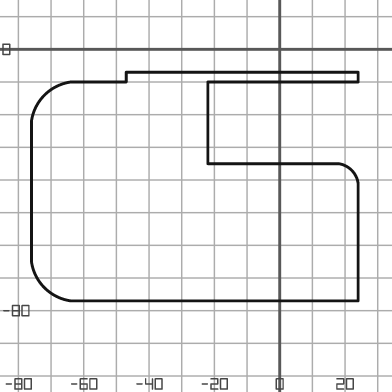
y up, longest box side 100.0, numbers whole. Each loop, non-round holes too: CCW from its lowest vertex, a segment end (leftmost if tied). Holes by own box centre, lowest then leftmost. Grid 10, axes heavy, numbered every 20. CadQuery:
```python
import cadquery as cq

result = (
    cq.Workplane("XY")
    .moveTo(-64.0, -77.0)
    .lineTo(24.0, -77.0)
    .lineTo(24.0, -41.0)
    .threePointArc((22.0, -37.0), (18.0, -35.0))
    .lineTo(-22.0, -35.0)
    .lineTo(-22.0, -10.0)
    .lineTo(24.0, -10.0)
    .lineTo(24.0, -7.0)
    .lineTo(-47.0, -7.0)
    .lineTo(-47.0, -10.0)
    .lineTo(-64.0, -10.0)
    .threePointArc((-72.0, -14.0), (-76.0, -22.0))
    .lineTo(-76.0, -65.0)
    .threePointArc((-72.0, -73.0), (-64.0, -77.0))
    .close()
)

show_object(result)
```